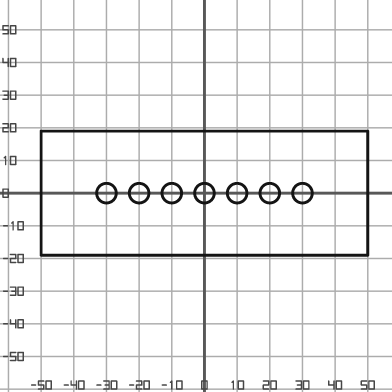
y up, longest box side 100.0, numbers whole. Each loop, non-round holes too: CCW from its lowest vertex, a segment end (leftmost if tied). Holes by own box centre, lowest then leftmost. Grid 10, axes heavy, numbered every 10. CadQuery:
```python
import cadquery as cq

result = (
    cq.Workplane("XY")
    .moveTo(-50.0, -19.0)
    .lineTo(50.0, -19.0)
    .lineTo(50.0, 19.0)
    .lineTo(-50.0, 19.0)
    .close()
    .moveTo(-30.0, 0.0)
    .circle(3.0)
    .moveTo(-20.0, 0.0)
    .circle(3.0)
    .moveTo(-10.0, 0.0)
    .circle(3.0)
    .moveTo(0.0, 0.0)
    .circle(3.0)
    .moveTo(10.0, 0.0)
    .circle(3.0)
    .moveTo(20.0, 0.0)
    .circle(3.0)
    .moveTo(30.0, 0.0)
    .circle(3.0)
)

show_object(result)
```